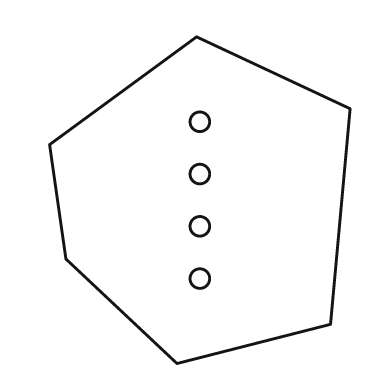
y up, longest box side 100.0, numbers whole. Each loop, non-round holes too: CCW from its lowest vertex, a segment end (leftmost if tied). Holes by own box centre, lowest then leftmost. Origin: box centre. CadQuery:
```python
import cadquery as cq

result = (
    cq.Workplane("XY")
    .moveTo(-7.0, -50.0)
    .lineTo(40.0, -38.0)
    .lineTo(46.0, 28.0)
    .lineTo(-1.0, 50.0)
    .lineTo(-46.0, 17.0)
    .lineTo(-41.0, -18.0)
    .close()
    .moveTo(0.0, -24.0)
    .circle(3.0)
    .moveTo(0.0, -8.0)
    .circle(3.0)
    .moveTo(0.0, 8.0)
    .circle(3.0)
    .moveTo(0.0, 24.0)
    .circle(3.0)
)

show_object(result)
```